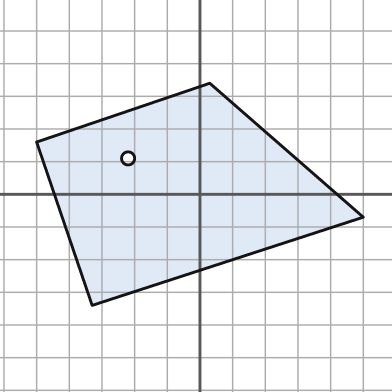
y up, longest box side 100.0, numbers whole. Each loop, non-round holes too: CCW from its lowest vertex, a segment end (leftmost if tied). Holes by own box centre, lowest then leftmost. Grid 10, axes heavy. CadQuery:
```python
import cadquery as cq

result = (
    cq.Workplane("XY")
    .moveTo(-33.0, -34.0)
    .lineTo(50.0, -7.0)
    .lineTo(3.0, 34.0)
    .lineTo(-50.0, 16.0)
    .close()
    .moveTo(-22.0, 11.0)
    .circle(2.0)
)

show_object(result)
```